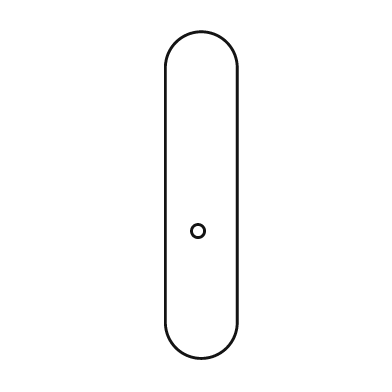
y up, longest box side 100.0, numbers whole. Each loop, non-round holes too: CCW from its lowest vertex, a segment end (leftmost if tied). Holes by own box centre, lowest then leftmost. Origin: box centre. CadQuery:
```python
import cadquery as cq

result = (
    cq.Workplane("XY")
    .moveTo(-11.0, -39.0)
    .threePointArc((0.0, -50.0), (11.0, -39.0))
    .lineTo(11.0, 39.0)
    .threePointArc((0.0, 50.0), (-11.0, 39.0))
    .close()
    .moveTo(-1.0, -11.0)
    .circle(2.0)
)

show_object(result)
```